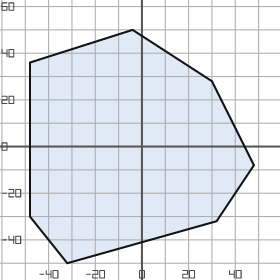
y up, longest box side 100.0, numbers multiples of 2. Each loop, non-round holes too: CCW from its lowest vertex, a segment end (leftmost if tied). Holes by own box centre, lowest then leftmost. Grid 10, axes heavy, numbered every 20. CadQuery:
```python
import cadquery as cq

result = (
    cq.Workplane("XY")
    .moveTo(-32.0, -50.0)
    .lineTo(32.0, -32.0)
    .lineTo(48.0, -8.0)
    .lineTo(30.0, 28.0)
    .lineTo(-4.0, 50.0)
    .lineTo(-48.0, 36.0)
    .lineTo(-48.0, -30.0)
    .close()
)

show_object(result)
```